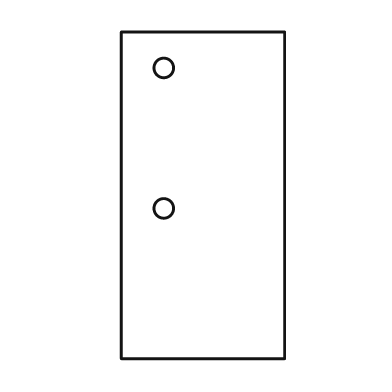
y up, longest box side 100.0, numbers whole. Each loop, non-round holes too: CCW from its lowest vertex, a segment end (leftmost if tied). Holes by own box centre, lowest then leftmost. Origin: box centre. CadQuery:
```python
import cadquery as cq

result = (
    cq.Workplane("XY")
    .moveTo(-25.0, -50.0)
    .lineTo(25.0, -50.0)
    .lineTo(25.0, 50.0)
    .lineTo(-25.0, 50.0)
    .close()
    .moveTo(-12.0, -4.0)
    .circle(3.0)
    .moveTo(-12.0, 39.0)
    .circle(3.0)
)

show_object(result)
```